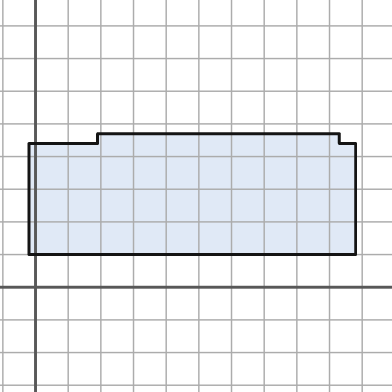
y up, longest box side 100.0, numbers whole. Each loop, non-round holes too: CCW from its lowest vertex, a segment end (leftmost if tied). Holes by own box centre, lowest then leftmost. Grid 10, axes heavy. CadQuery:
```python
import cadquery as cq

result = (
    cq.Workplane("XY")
    .moveTo(-2.0, 10.0)
    .lineTo(98.0, 10.0)
    .lineTo(98.0, 44.0)
    .lineTo(93.0, 44.0)
    .lineTo(93.0, 47.0)
    .lineTo(19.0, 47.0)
    .lineTo(19.0, 44.0)
    .lineTo(-2.0, 44.0)
    .close()
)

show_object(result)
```